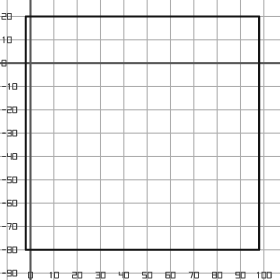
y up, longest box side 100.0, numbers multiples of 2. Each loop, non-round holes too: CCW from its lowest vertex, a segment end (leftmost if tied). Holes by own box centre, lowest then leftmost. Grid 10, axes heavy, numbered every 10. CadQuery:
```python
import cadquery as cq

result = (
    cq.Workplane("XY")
    .moveTo(-2.0, -80.0)
    .lineTo(98.0, -80.0)
    .lineTo(98.0, 20.0)
    .lineTo(-2.0, 20.0)
    .close()
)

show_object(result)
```